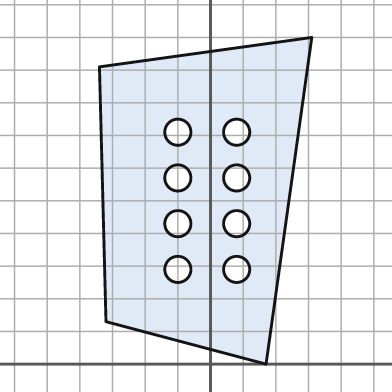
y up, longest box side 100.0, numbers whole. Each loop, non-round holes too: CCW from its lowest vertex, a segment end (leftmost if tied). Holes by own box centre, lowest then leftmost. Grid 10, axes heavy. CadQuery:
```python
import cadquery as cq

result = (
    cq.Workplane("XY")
    .moveTo(17.0, 0.0)
    .lineTo(31.0, 100.0)
    .lineTo(-34.0, 91.0)
    .lineTo(-32.0, 13.0)
    .close()
    .moveTo(-10.0, 29.0)
    .circle(4.0)
    .moveTo(8.0, 29.0)
    .circle(4.0)
    .moveTo(-10.0, 43.0)
    .circle(4.0)
    .moveTo(8.0, 43.0)
    .circle(4.0)
    .moveTo(-10.0, 57.0)
    .circle(4.0)
    .moveTo(8.0, 57.0)
    .circle(4.0)
    .moveTo(-10.0, 71.0)
    .circle(4.0)
    .moveTo(8.0, 71.0)
    .circle(4.0)
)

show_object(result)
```